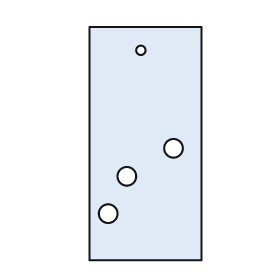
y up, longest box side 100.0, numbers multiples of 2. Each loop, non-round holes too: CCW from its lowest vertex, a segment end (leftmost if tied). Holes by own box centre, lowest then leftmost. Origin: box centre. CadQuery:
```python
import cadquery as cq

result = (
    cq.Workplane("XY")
    .moveTo(-24.0, -50.0)
    .lineTo(24.0, -50.0)
    .lineTo(24.0, 50.0)
    .lineTo(-24.0, 50.0)
    .close()
    .moveTo(-16.0, -30.0)
    .circle(4.0)
    .moveTo(-8.0, -14.0)
    .circle(4.0)
    .moveTo(12.0, -2.0)
    .circle(4.0)
    .moveTo(-2.0, 40.0)
    .circle(2.0)
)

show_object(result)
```